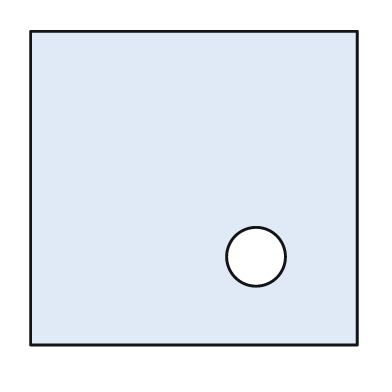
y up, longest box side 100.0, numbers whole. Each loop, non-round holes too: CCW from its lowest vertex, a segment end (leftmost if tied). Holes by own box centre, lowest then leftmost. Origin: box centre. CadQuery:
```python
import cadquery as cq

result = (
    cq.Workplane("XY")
    .moveTo(-50.0, -48.0)
    .lineTo(50.0, -48.0)
    .lineTo(50.0, 48.0)
    .lineTo(-50.0, 48.0)
    .close()
    .moveTo(19.0, -21.0)
    .circle(9.0)
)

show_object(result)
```